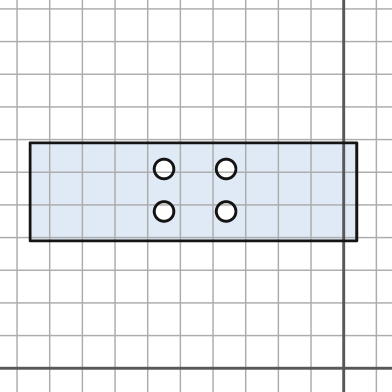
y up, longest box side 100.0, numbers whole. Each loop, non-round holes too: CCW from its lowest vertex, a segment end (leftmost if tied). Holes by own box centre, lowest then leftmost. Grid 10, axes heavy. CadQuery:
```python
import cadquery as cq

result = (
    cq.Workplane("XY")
    .moveTo(-96.0, 39.0)
    .lineTo(4.0, 39.0)
    .lineTo(4.0, 69.0)
    .lineTo(-96.0, 69.0)
    .close()
    .moveTo(-55.0, 48.0)
    .circle(3.0)
    .moveTo(-36.0, 48.0)
    .circle(3.0)
    .moveTo(-55.0, 61.0)
    .circle(3.0)
    .moveTo(-36.0, 61.0)
    .circle(3.0)
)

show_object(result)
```